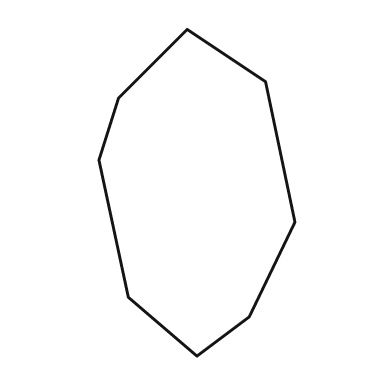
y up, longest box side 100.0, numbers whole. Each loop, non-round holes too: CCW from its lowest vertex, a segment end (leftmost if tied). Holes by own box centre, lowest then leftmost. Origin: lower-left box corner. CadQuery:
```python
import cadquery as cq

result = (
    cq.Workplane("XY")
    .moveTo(30.0, 0.0)
    .lineTo(46.0, 12.0)
    .lineTo(60.0, 41.0)
    .lineTo(51.0, 84.0)
    .lineTo(27.0, 100.0)
    .lineTo(6.0, 79.0)
    .lineTo(0.0, 60.0)
    .lineTo(9.0, 18.0)
    .close()
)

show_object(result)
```